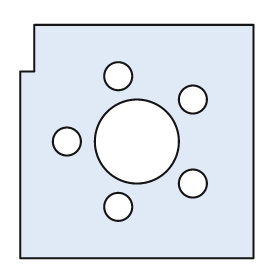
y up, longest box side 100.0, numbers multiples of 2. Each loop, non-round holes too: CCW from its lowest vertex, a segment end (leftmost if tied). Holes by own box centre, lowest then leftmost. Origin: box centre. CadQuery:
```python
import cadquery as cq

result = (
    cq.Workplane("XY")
    .moveTo(-50.0, -50.0)
    .lineTo(50.0, -50.0)
    .lineTo(50.0, 50.0)
    .lineTo(-44.0, 50.0)
    .lineTo(-44.0, 30.0)
    .lineTo(-50.0, 30.0)
    .close()
    .moveTo(-8.0, -28.0)
    .circle(6.0)
    .moveTo(24.0, -18.0)
    .circle(6.0)
    .moveTo(-30.0, 0.0)
    .circle(6.0)
    .moveTo(0.0, 0.0)
    .circle(18.0)
    .moveTo(24.0, 18.0)
    .circle(6.0)
    .moveTo(-8.0, 28.0)
    .circle(6.0)
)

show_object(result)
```